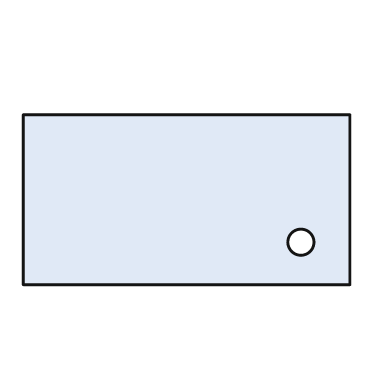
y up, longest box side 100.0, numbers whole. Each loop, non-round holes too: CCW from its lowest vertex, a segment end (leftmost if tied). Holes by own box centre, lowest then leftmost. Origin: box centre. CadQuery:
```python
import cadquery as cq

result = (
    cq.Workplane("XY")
    .moveTo(-50.0, -26.0)
    .lineTo(50.0, -26.0)
    .lineTo(50.0, 26.0)
    .lineTo(-50.0, 26.0)
    .close()
    .moveTo(35.0, -13.0)
    .circle(4.0)
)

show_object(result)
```